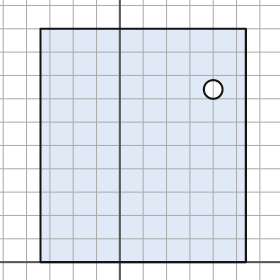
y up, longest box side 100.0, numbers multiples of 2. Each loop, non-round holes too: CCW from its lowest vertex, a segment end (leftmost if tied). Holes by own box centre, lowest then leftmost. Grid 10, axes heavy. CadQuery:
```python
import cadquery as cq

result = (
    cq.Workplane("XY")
    .moveTo(-34.0, 0.0)
    .lineTo(54.0, 0.0)
    .lineTo(54.0, 100.0)
    .lineTo(-34.0, 100.0)
    .close()
    .moveTo(40.0, 74.0)
    .circle(4.0)
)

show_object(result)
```